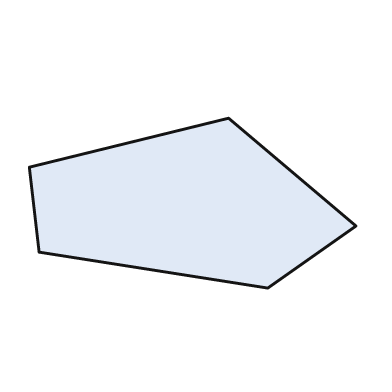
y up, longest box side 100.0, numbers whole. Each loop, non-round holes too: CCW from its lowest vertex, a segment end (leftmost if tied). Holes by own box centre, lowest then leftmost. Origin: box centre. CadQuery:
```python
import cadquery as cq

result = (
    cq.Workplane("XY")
    .moveTo(23.0, -26.0)
    .lineTo(50.0, -7.0)
    .lineTo(11.0, 26.0)
    .lineTo(-50.0, 11.0)
    .lineTo(-47.0, -15.0)
    .close()
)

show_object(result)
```